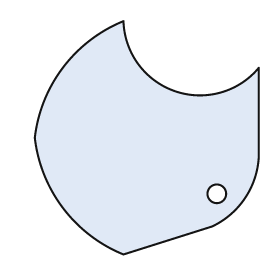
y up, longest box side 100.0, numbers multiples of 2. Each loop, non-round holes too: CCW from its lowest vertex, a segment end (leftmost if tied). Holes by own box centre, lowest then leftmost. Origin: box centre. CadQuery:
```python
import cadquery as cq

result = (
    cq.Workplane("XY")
    .moveTo(-10.0, -50.0)
    .lineTo(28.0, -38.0)
    .threePointArc((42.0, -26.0), (48.0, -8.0))
    .lineTo(48.0, 30.0)
    .threePointArc((12.0, 20.0), (-10.0, 50.0))
    .threePointArc((-36.0, 30.0), (-48.0, 0.0))
    .threePointArc((-36.0, -30.0), (-10.0, -50.0))
    .close()
    .moveTo(30.0, -24.0)
    .circle(4.0)
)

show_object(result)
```